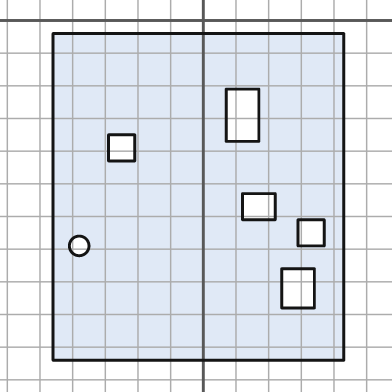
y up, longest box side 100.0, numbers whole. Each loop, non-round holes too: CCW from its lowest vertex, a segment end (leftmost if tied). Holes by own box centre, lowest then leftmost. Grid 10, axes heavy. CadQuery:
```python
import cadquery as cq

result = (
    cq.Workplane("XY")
    .moveTo(-46.0, -104.0)
    .lineTo(43.0, -104.0)
    .lineTo(43.0, -4.0)
    .lineTo(-46.0, -4.0)
    .close()
    .moveTo(24.0, -88.0)
    .lineTo(34.0, -88.0)
    .lineTo(34.0, -76.0)
    .lineTo(24.0, -76.0)
    .close()
    .moveTo(-38.0, -69.0)
    .circle(3.0)
    .moveTo(29.0, -69.0)
    .lineTo(37.0, -69.0)
    .lineTo(37.0, -61.0)
    .lineTo(29.0, -61.0)
    .close()
    .moveTo(12.0, -61.0)
    .lineTo(22.0, -61.0)
    .lineTo(22.0, -53.0)
    .lineTo(12.0, -53.0)
    .close()
    .moveTo(-29.0, -43.0)
    .lineTo(-21.0, -43.0)
    .lineTo(-21.0, -35.0)
    .lineTo(-29.0, -35.0)
    .close()
    .moveTo(7.0, -37.0)
    .lineTo(17.0, -37.0)
    .lineTo(17.0, -21.0)
    .lineTo(7.0, -21.0)
    .close()
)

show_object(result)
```